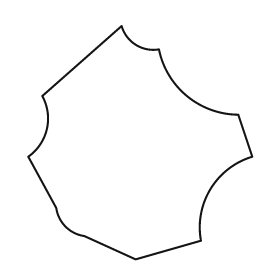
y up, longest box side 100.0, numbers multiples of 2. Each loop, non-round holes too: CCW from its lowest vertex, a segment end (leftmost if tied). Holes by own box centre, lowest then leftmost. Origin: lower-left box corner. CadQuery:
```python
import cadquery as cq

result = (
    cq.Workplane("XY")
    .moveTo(46.0, 0.0)
    .lineTo(74.0, 8.0)
    .threePointArc((78.0, 30.0), (96.0, 44.0))
    .lineTo(90.0, 62.0)
    .threePointArc((68.0, 70.0), (56.0, 90.0))
    .threePointArc((46.0, 92.0), (40.0, 100.0))
    .lineTo(6.0, 70.0)
    .threePointArc((8.0, 56.0), (0.0, 44.0))
    .lineTo(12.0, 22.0)
    .threePointArc((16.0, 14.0), (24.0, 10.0))
    .close()
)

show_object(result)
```